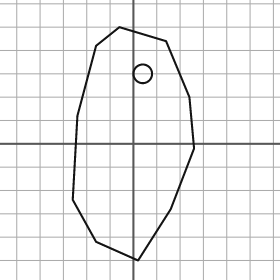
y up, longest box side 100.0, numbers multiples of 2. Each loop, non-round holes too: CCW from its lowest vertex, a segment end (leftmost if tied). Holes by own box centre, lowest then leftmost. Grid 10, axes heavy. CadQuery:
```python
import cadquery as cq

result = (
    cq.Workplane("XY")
    .moveTo(2.0, -50.0)
    .lineTo(16.0, -28.0)
    .lineTo(26.0, -2.0)
    .lineTo(24.0, 20.0)
    .lineTo(14.0, 44.0)
    .lineTo(-6.0, 50.0)
    .lineTo(-16.0, 42.0)
    .lineTo(-24.0, 12.0)
    .lineTo(-26.0, -24.0)
    .lineTo(-16.0, -42.0)
    .close()
    .moveTo(4.0, 30.0)
    .circle(4.0)
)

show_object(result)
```